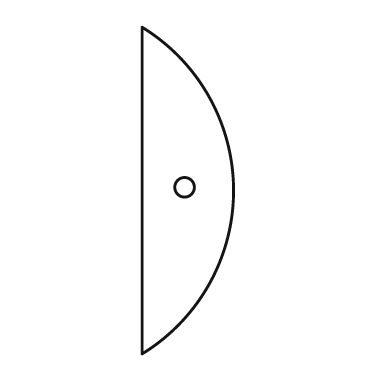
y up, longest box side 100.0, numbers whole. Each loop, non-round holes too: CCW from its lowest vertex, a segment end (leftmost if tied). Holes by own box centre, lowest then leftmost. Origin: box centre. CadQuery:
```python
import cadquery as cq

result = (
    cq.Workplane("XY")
    .moveTo(-14.0, -50.0)
    .threePointArc((14.0, 0.0), (-14.0, 50.0))
    .close()
    .moveTo(-1.0, 1.0)
    .circle(3.0)
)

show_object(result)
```